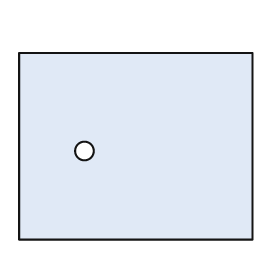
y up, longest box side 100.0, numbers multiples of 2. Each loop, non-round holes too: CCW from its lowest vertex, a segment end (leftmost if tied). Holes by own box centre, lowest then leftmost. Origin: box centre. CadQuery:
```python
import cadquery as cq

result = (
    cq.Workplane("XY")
    .moveTo(-50.0, -40.0)
    .lineTo(50.0, -40.0)
    .lineTo(50.0, 40.0)
    .lineTo(-50.0, 40.0)
    .close()
    .moveTo(-22.0, -2.0)
    .circle(4.0)
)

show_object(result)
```